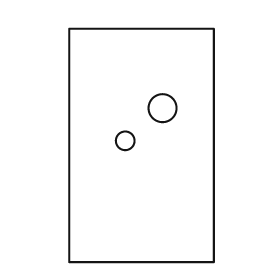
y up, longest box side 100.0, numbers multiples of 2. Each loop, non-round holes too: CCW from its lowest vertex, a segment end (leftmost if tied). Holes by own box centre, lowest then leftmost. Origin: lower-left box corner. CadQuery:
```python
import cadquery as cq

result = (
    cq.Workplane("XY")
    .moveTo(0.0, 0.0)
    .lineTo(62.0, 0.0)
    .lineTo(62.0, 100.0)
    .lineTo(0.0, 100.0)
    .close()
    .moveTo(24.0, 52.0)
    .circle(4.0)
    .moveTo(40.0, 66.0)
    .circle(6.0)
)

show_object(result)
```